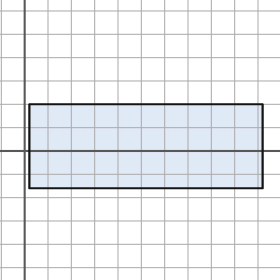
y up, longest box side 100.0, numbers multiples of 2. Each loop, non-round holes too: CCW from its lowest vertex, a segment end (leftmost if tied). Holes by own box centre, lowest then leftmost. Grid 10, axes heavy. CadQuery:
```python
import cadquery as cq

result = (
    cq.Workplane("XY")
    .moveTo(2.0, -16.0)
    .lineTo(102.0, -16.0)
    .lineTo(102.0, 20.0)
    .lineTo(2.0, 20.0)
    .close()
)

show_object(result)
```